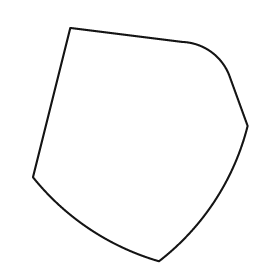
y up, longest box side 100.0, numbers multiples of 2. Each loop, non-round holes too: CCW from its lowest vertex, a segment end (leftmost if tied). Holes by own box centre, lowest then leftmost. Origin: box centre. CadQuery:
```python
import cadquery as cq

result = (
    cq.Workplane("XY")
    .moveTo(8.0, -50.0)
    .threePointArc((32.0, -24.0), (46.0, 8.0))
    .lineTo(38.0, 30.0)
    .threePointArc((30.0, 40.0), (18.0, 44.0))
    .lineTo(-30.0, 50.0)
    .lineTo(-46.0, -14.0)
    .threePointArc((-22.0, -36.0), (8.0, -50.0))
    .close()
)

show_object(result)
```